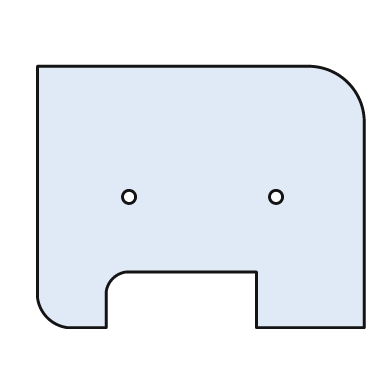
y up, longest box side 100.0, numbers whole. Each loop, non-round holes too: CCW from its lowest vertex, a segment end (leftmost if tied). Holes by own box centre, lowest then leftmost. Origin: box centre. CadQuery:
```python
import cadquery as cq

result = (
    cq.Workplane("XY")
    .moveTo(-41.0, -40.0)
    .lineTo(-29.0, -40.0)
    .lineTo(-29.0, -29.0)
    .threePointArc((-27.0, -25.0), (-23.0, -23.0))
    .lineTo(17.0, -23.0)
    .lineTo(17.0, -40.0)
    .lineTo(50.0, -40.0)
    .lineTo(50.0, 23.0)
    .threePointArc((45.0, 35.0), (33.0, 40.0))
    .lineTo(-50.0, 40.0)
    .lineTo(-50.0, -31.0)
    .threePointArc((-47.0, -37.0), (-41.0, -40.0))
    .close()
    .moveTo(-22.0, 0.0)
    .circle(2.0)
    .moveTo(23.0, 0.0)
    .circle(2.0)
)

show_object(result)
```